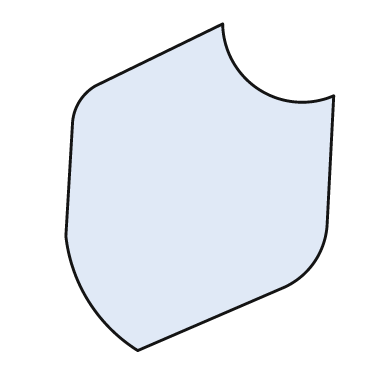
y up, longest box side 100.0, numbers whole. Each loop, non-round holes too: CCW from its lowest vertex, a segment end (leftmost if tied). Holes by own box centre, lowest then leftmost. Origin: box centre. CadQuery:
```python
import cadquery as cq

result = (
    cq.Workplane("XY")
    .moveTo(-19.0, -50.0)
    .lineTo(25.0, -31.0)
    .threePointArc((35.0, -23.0), (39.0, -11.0))
    .lineTo(41.0, 28.0)
    .threePointArc((18.0, 30.0), (7.0, 50.0))
    .lineTo(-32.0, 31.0)
    .threePointArc((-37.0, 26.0), (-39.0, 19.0))
    .lineTo(-41.0, -15.0)
    .threePointArc((-34.0, -35.0), (-19.0, -50.0))
    .close()
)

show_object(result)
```